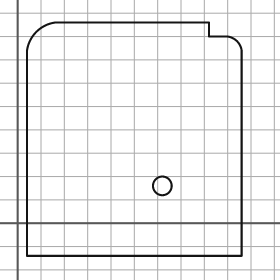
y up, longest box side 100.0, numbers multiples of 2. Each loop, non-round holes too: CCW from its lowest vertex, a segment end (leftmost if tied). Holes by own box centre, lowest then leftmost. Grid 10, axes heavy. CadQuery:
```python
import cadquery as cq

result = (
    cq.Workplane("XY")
    .moveTo(4.0, -14.0)
    .lineTo(96.0, -14.0)
    .lineTo(96.0, 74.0)
    .threePointArc((94.0, 78.0), (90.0, 80.0))
    .lineTo(82.0, 80.0)
    .lineTo(82.0, 86.0)
    .lineTo(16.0, 86.0)
    .threePointArc((8.0, 82.0), (4.0, 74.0))
    .close()
    .moveTo(62.0, 16.0)
    .circle(4.0)
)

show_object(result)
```